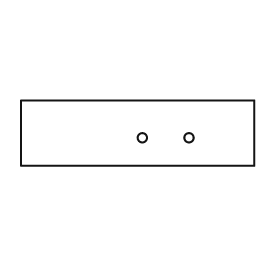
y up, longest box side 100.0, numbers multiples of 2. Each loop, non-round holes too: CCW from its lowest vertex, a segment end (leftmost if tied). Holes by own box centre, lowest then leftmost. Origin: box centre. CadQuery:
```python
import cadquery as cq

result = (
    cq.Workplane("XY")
    .moveTo(-50.0, -14.0)
    .lineTo(50.0, -14.0)
    .lineTo(50.0, 14.0)
    .lineTo(-50.0, 14.0)
    .close()
    .moveTo(2.0, -2.0)
    .circle(2.0)
    .moveTo(22.0, -2.0)
    .circle(2.0)
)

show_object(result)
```